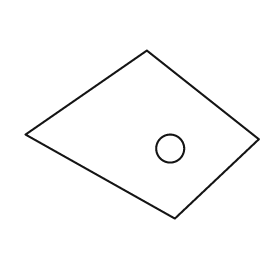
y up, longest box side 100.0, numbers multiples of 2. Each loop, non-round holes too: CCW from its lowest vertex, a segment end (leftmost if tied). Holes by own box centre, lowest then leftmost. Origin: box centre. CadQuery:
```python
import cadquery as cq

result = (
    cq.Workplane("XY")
    .moveTo(14.0, -36.0)
    .lineTo(50.0, -2.0)
    .lineTo(2.0, 36.0)
    .lineTo(-50.0, 0.0)
    .close()
    .moveTo(12.0, -6.0)
    .circle(6.0)
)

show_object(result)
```